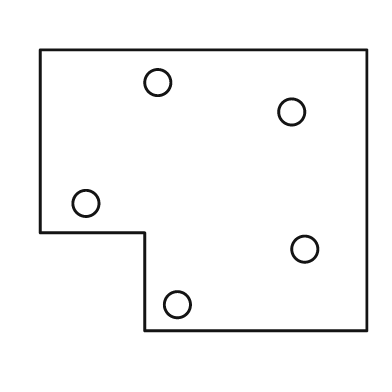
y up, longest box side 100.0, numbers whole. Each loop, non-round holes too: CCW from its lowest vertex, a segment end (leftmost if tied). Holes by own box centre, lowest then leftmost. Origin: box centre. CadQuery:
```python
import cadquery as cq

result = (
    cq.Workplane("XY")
    .moveTo(-18.0, -43.0)
    .lineTo(50.0, -43.0)
    .lineTo(50.0, 43.0)
    .lineTo(-50.0, 43.0)
    .lineTo(-50.0, -13.0)
    .lineTo(-18.0, -13.0)
    .close()
    .moveTo(-8.0, -35.0)
    .circle(4.0)
    .moveTo(31.0, -18.0)
    .circle(4.0)
    .moveTo(-36.0, -4.0)
    .circle(4.0)
    .moveTo(27.0, 24.0)
    .circle(4.0)
    .moveTo(-14.0, 33.0)
    .circle(4.0)
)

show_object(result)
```